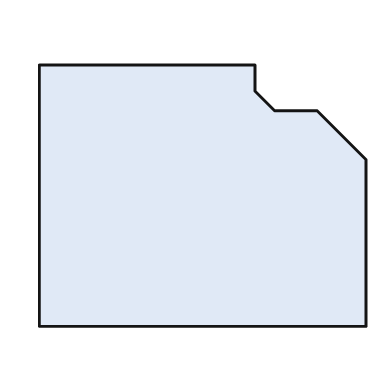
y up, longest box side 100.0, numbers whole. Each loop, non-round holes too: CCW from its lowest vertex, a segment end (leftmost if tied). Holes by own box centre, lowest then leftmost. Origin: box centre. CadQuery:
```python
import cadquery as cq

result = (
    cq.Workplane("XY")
    .moveTo(-50.0, -40.0)
    .lineTo(50.0, -40.0)
    .lineTo(50.0, 11.0)
    .lineTo(35.0, 26.0)
    .lineTo(22.0, 26.0)
    .lineTo(16.0, 32.0)
    .lineTo(16.0, 40.0)
    .lineTo(-50.0, 40.0)
    .close()
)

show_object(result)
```